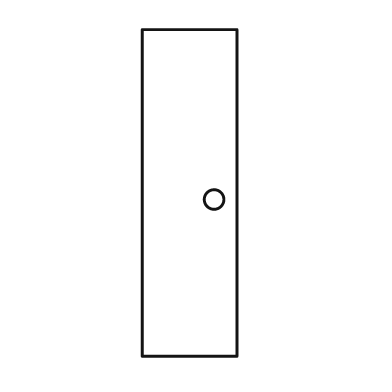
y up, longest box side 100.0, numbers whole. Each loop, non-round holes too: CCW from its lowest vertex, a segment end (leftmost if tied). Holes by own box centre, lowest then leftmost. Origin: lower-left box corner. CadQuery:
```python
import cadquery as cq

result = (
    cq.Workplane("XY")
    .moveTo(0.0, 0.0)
    .lineTo(29.0, 0.0)
    .lineTo(29.0, 100.0)
    .lineTo(0.0, 100.0)
    .close()
    .moveTo(22.0, 48.0)
    .circle(3.0)
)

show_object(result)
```